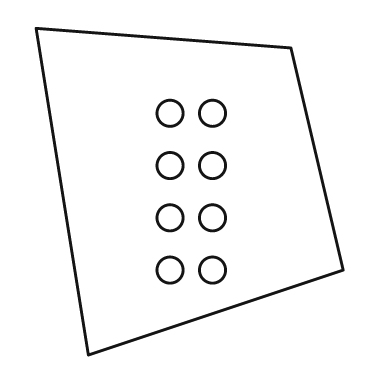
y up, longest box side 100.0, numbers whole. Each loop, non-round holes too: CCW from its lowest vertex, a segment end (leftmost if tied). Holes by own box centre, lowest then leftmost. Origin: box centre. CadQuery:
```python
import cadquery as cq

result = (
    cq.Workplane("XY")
    .moveTo(-31.0, -50.0)
    .lineTo(47.0, -24.0)
    .lineTo(31.0, 44.0)
    .lineTo(-47.0, 50.0)
    .close()
    .moveTo(-6.0, -24.0)
    .circle(4.0)
    .moveTo(7.0, -24.0)
    .circle(4.0)
    .moveTo(-6.0, -8.0)
    .circle(4.0)
    .moveTo(7.0, -8.0)
    .circle(4.0)
    .moveTo(-6.0, 8.0)
    .circle(4.0)
    .moveTo(7.0, 8.0)
    .circle(4.0)
    .moveTo(-6.0, 24.0)
    .circle(4.0)
    .moveTo(7.0, 24.0)
    .circle(4.0)
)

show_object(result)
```